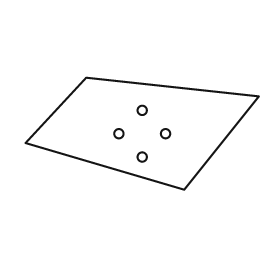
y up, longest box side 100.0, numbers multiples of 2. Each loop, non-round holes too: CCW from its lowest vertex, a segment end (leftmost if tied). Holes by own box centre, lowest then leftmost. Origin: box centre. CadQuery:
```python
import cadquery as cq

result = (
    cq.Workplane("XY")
    .moveTo(18.0, -24.0)
    .lineTo(50.0, 16.0)
    .lineTo(-24.0, 24.0)
    .lineTo(-50.0, -4.0)
    .close()
    .moveTo(0.0, -10.0)
    .circle(2.0)
    .moveTo(-10.0, 0.0)
    .circle(2.0)
    .moveTo(10.0, 0.0)
    .circle(2.0)
    .moveTo(0.0, 10.0)
    .circle(2.0)
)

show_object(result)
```